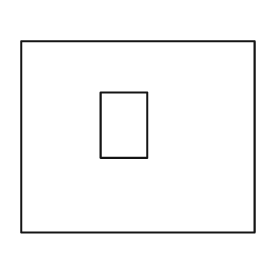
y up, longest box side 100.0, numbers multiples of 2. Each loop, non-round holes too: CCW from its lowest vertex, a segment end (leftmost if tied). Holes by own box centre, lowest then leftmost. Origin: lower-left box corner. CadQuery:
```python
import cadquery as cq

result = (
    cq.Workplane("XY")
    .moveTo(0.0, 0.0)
    .lineTo(100.0, 0.0)
    .lineTo(100.0, 82.0)
    .lineTo(0.0, 82.0)
    .close()
    .moveTo(34.0, 32.0)
    .lineTo(54.0, 32.0)
    .lineTo(54.0, 60.0)
    .lineTo(34.0, 60.0)
    .close()
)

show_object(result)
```